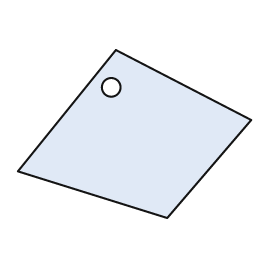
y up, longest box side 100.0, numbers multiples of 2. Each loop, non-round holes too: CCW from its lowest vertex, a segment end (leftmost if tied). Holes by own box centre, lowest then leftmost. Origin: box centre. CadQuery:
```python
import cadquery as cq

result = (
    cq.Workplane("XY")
    .moveTo(14.0, -36.0)
    .lineTo(50.0, 6.0)
    .lineTo(-8.0, 36.0)
    .lineTo(-50.0, -16.0)
    .close()
    .moveTo(-10.0, 20.0)
    .circle(4.0)
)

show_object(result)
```